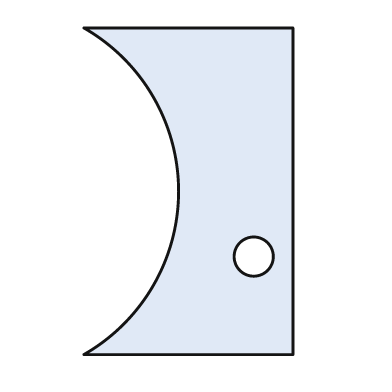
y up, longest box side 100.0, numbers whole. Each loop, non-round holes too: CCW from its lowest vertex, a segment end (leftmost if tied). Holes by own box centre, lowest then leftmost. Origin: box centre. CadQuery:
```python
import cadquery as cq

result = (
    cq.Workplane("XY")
    .moveTo(-32.0, -50.0)
    .lineTo(32.0, -50.0)
    .lineTo(32.0, 50.0)
    .lineTo(-32.0, 50.0)
    .threePointArc((-3.0, 0.0), (-32.0, -50.0))
    .close()
    .moveTo(20.0, -20.0)
    .circle(6.0)
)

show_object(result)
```